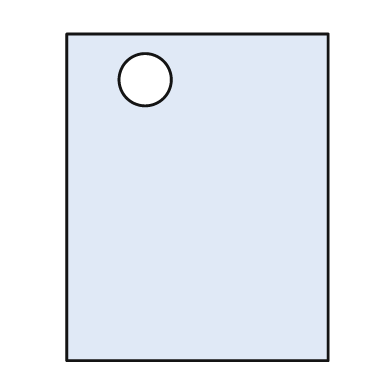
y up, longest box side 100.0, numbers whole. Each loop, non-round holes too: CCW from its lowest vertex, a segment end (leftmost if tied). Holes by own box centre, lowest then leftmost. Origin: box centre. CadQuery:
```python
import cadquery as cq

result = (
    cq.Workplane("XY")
    .moveTo(-40.0, -50.0)
    .lineTo(40.0, -50.0)
    .lineTo(40.0, 50.0)
    .lineTo(-40.0, 50.0)
    .close()
    .moveTo(-16.0, 36.0)
    .circle(8.0)
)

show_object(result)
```